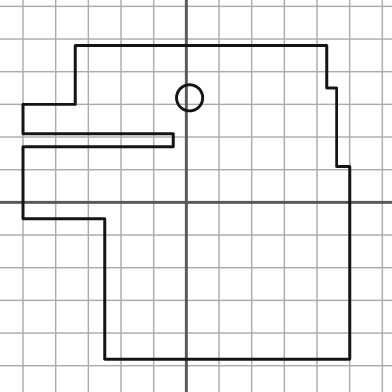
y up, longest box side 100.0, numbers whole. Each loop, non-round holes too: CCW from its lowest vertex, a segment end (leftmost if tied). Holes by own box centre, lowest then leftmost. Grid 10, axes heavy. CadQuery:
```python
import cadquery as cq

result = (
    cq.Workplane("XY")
    .moveTo(-25.0, -48.0)
    .lineTo(50.0, -48.0)
    .lineTo(50.0, 11.0)
    .lineTo(46.0, 11.0)
    .lineTo(46.0, 35.0)
    .lineTo(43.0, 35.0)
    .lineTo(43.0, 48.0)
    .lineTo(-34.0, 48.0)
    .lineTo(-34.0, 30.0)
    .lineTo(-50.0, 30.0)
    .lineTo(-50.0, 21.0)
    .lineTo(-4.0, 21.0)
    .lineTo(-4.0, 17.0)
    .lineTo(-50.0, 17.0)
    .lineTo(-50.0, -5.0)
    .lineTo(-25.0, -5.0)
    .close()
    .moveTo(1.0, 32.0)
    .circle(4.0)
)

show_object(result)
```